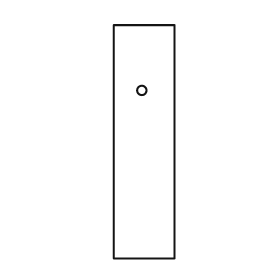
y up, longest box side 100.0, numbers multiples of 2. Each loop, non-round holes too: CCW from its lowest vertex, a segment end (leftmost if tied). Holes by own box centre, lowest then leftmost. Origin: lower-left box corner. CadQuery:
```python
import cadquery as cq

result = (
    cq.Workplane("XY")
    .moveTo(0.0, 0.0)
    .lineTo(26.0, 0.0)
    .lineTo(26.0, 100.0)
    .lineTo(0.0, 100.0)
    .close()
    .moveTo(12.0, 72.0)
    .circle(2.0)
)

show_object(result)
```